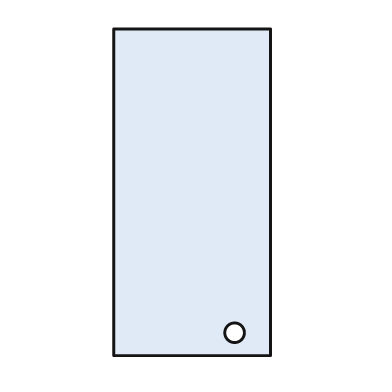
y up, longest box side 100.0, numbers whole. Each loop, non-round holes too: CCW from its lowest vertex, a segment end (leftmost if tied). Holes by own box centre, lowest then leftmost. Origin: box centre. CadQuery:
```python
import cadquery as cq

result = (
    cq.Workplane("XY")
    .moveTo(-24.0, -50.0)
    .lineTo(24.0, -50.0)
    .lineTo(24.0, 50.0)
    .lineTo(-24.0, 50.0)
    .close()
    .moveTo(13.0, -43.0)
    .circle(3.0)
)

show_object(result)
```